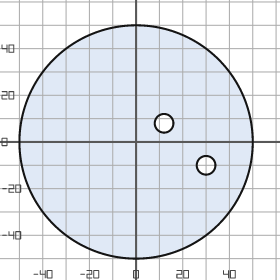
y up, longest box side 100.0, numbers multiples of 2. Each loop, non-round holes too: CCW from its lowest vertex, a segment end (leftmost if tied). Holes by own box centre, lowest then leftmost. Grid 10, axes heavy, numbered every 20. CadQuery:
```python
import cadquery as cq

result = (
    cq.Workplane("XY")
    .moveTo(0.0, 0.0)
    .circle(50.0)
    .moveTo(30.0, -10.0)
    .circle(4.0)
    .moveTo(12.0, 8.0)
    .circle(4.0)
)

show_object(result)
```